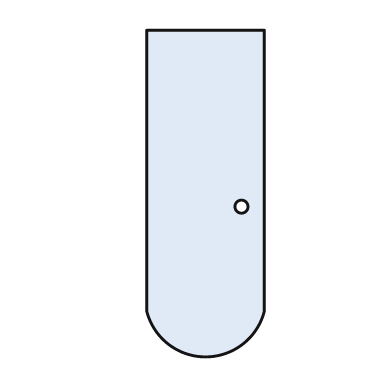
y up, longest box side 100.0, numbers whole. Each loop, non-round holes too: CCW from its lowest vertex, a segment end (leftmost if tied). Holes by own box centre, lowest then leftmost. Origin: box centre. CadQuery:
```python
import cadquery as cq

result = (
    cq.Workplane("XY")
    .moveTo(-18.0, -36.0)
    .threePointArc((0.0, -50.0), (18.0, -36.0))
    .lineTo(18.0, 50.0)
    .lineTo(-18.0, 50.0)
    .close()
    .moveTo(11.0, -4.0)
    .circle(2.0)
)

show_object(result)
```